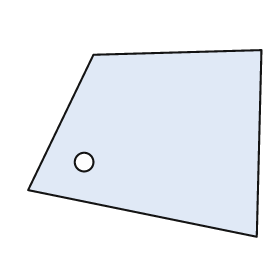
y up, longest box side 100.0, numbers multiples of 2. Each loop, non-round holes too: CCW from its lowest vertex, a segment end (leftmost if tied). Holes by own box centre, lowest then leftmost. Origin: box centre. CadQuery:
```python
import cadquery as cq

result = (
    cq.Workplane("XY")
    .moveTo(48.0, -40.0)
    .lineTo(50.0, 40.0)
    .lineTo(-22.0, 38.0)
    .lineTo(-50.0, -20.0)
    .close()
    .moveTo(-26.0, -8.0)
    .circle(4.0)
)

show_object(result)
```